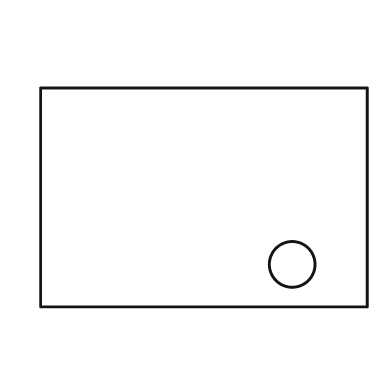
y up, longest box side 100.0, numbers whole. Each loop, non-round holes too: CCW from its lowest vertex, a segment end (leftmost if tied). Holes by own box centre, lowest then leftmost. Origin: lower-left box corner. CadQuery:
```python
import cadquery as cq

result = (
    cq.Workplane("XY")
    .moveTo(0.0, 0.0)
    .lineTo(100.0, 0.0)
    .lineTo(100.0, 67.0)
    .lineTo(0.0, 67.0)
    .close()
    .moveTo(77.0, 13.0)
    .circle(7.0)
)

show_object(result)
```